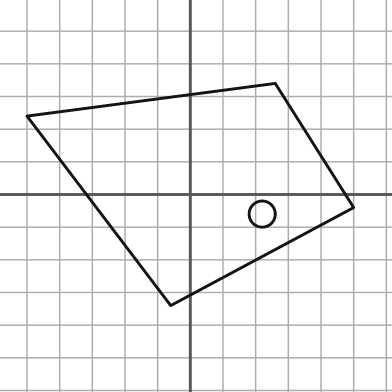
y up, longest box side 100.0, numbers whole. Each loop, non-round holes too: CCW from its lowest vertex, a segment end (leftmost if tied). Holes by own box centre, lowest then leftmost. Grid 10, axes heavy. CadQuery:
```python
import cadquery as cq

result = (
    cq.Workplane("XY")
    .moveTo(-6.0, -34.0)
    .lineTo(50.0, -4.0)
    .lineTo(26.0, 34.0)
    .lineTo(-50.0, 24.0)
    .close()
    .moveTo(22.0, -6.0)
    .circle(4.0)
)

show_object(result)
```